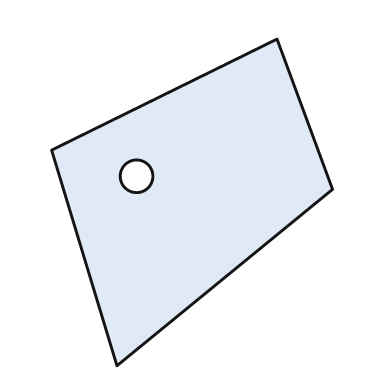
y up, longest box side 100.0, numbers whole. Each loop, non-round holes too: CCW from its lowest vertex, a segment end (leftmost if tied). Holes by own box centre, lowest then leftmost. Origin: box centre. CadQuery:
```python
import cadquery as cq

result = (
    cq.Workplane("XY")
    .moveTo(-23.0, -50.0)
    .lineTo(43.0, 4.0)
    .lineTo(26.0, 50.0)
    .lineTo(-43.0, 16.0)
    .close()
    .moveTo(-17.0, 8.0)
    .circle(5.0)
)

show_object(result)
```